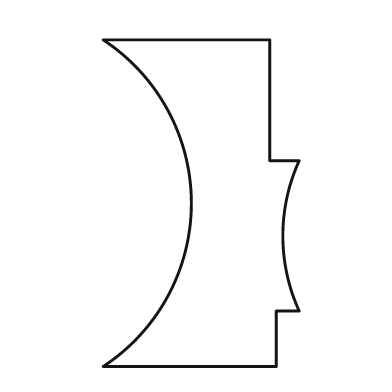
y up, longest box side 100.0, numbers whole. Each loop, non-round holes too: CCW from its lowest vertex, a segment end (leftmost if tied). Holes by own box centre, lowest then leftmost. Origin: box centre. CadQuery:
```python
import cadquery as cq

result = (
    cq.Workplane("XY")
    .moveTo(-30.0, -50.0)
    .lineTo(23.0, -50.0)
    .lineTo(23.0, -33.0)
    .lineTo(30.0, -33.0)
    .threePointArc((25.0, -10.0), (30.0, 13.0))
    .lineTo(21.0, 13.0)
    .lineTo(21.0, 50.0)
    .lineTo(-30.0, 50.0)
    .threePointArc((-3.0, 0.0), (-30.0, -50.0))
    .close()
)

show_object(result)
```